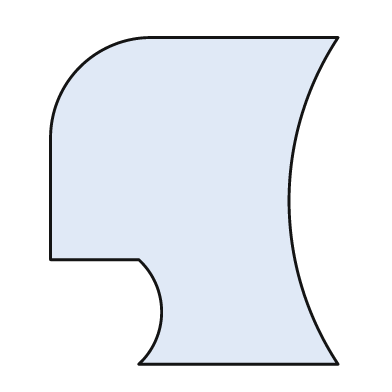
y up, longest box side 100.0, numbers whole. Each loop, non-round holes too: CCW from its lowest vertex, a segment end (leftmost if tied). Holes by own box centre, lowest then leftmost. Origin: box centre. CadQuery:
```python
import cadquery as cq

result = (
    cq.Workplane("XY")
    .moveTo(-17.0, -50.0)
    .lineTo(44.0, -50.0)
    .threePointArc((29.0, 0.0), (44.0, 50.0))
    .lineTo(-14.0, 50.0)
    .threePointArc((-35.0, 41.0), (-44.0, 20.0))
    .lineTo(-44.0, -18.0)
    .lineTo(-17.0, -18.0)
    .threePointArc((-10.0, -34.0), (-17.0, -50.0))
    .close()
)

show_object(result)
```